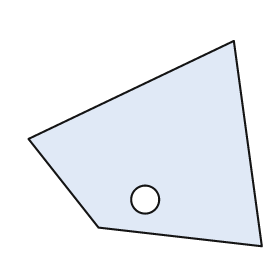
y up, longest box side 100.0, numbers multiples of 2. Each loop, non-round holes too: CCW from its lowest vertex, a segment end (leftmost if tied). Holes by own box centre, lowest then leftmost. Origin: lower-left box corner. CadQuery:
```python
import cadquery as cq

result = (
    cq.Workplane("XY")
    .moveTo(100.0, 0.0)
    .lineTo(88.0, 88.0)
    .lineTo(0.0, 46.0)
    .lineTo(30.0, 8.0)
    .close()
    .moveTo(50.0, 20.0)
    .circle(6.0)
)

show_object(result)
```